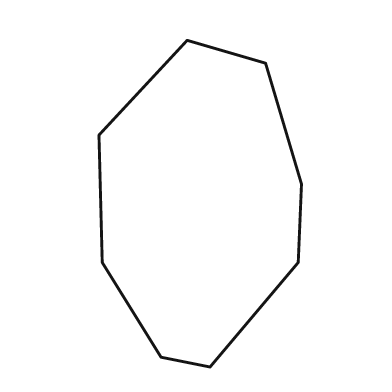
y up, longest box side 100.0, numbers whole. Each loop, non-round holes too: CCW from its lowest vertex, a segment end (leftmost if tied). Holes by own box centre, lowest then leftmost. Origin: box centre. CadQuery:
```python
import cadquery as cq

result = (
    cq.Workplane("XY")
    .moveTo(3.0, -50.0)
    .lineTo(30.0, -18.0)
    .lineTo(31.0, 6.0)
    .lineTo(20.0, 43.0)
    .lineTo(-4.0, 50.0)
    .lineTo(-31.0, 21.0)
    .lineTo(-30.0, -18.0)
    .lineTo(-12.0, -47.0)
    .close()
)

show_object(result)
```